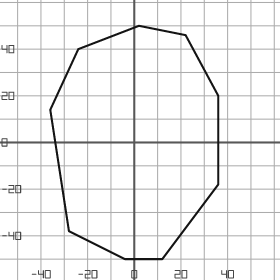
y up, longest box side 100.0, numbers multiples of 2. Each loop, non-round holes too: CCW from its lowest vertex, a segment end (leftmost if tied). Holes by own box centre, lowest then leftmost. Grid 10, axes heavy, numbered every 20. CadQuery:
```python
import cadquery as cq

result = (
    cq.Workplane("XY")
    .moveTo(-4.0, -50.0)
    .lineTo(12.0, -50.0)
    .lineTo(36.0, -18.0)
    .lineTo(36.0, 20.0)
    .lineTo(22.0, 46.0)
    .lineTo(2.0, 50.0)
    .lineTo(-24.0, 40.0)
    .lineTo(-36.0, 14.0)
    .lineTo(-28.0, -38.0)
    .close()
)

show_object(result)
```